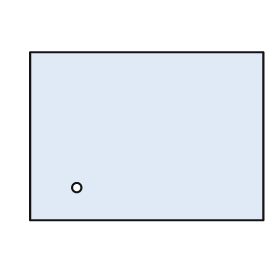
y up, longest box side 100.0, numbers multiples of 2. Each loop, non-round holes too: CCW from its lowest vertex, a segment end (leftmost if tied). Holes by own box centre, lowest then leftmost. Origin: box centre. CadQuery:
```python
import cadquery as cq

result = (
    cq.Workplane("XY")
    .moveTo(-50.0, -36.0)
    .lineTo(50.0, -36.0)
    .lineTo(50.0, 36.0)
    .lineTo(-50.0, 36.0)
    .close()
    .moveTo(-30.0, -22.0)
    .circle(2.0)
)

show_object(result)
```